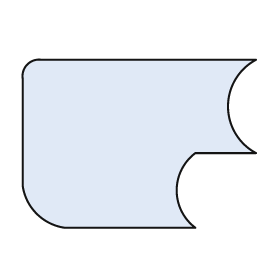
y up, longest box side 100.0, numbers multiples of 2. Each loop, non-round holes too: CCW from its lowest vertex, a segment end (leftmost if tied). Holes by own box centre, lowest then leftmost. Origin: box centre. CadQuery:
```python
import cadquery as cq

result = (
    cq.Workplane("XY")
    .moveTo(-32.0, -36.0)
    .lineTo(24.0, -36.0)
    .threePointArc((16.0, -20.0), (24.0, -4.0))
    .lineTo(50.0, -4.0)
    .threePointArc((38.0, 16.0), (50.0, 36.0))
    .lineTo(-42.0, 36.0)
    .threePointArc((-48.0, 34.0), (-50.0, 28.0))
    .lineTo(-50.0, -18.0)
    .threePointArc((-44.0, -30.0), (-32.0, -36.0))
    .close()
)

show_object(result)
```